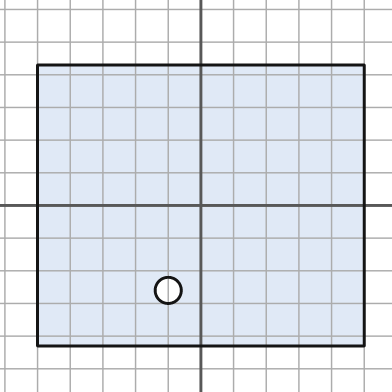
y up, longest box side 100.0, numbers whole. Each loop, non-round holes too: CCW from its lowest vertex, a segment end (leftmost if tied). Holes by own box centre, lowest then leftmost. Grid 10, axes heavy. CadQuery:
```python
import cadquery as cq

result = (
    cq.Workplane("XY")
    .moveTo(-50.0, -43.0)
    .lineTo(50.0, -43.0)
    .lineTo(50.0, 43.0)
    .lineTo(-50.0, 43.0)
    .close()
    .moveTo(-10.0, -26.0)
    .circle(4.0)
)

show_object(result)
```